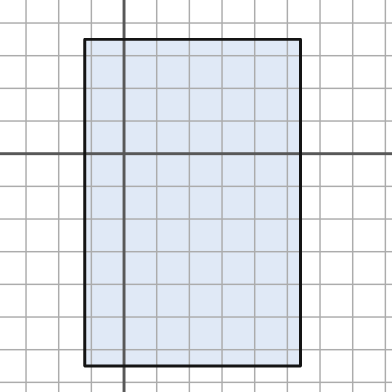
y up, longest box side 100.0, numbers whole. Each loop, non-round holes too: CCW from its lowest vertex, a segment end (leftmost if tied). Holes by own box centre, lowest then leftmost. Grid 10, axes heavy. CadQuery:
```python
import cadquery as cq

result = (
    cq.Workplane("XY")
    .moveTo(-12.0, -65.0)
    .lineTo(54.0, -65.0)
    .lineTo(54.0, 35.0)
    .lineTo(-12.0, 35.0)
    .close()
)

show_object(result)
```